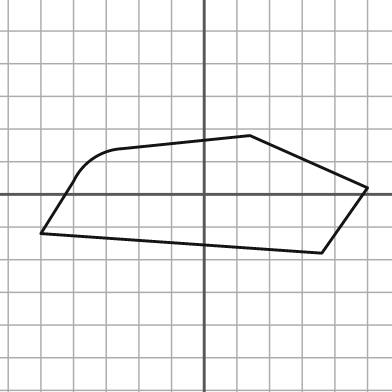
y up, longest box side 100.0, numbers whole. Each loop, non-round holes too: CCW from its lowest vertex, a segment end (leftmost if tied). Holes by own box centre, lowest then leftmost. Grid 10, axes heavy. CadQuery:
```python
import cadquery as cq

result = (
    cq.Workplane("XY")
    .moveTo(36.0, -18.0)
    .lineTo(50.0, 2.0)
    .lineTo(14.0, 18.0)
    .lineTo(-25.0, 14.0)
    .threePointArc((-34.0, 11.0), (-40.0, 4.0))
    .lineTo(-50.0, -12.0)
    .close()
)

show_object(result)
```